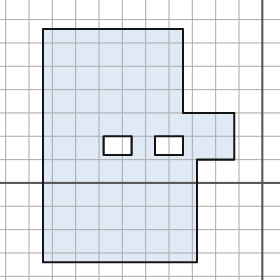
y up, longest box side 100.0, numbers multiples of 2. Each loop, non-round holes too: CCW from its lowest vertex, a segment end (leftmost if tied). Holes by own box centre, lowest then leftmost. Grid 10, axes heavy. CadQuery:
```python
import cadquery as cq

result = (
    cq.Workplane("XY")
    .moveTo(-94.0, -34.0)
    .lineTo(-28.0, -34.0)
    .lineTo(-28.0, 10.0)
    .lineTo(-12.0, 10.0)
    .lineTo(-12.0, 30.0)
    .lineTo(-34.0, 30.0)
    .lineTo(-34.0, 66.0)
    .lineTo(-94.0, 66.0)
    .close()
    .moveTo(-68.0, 12.0)
    .lineTo(-56.0, 12.0)
    .lineTo(-56.0, 20.0)
    .lineTo(-68.0, 20.0)
    .close()
    .moveTo(-46.0, 12.0)
    .lineTo(-34.0, 12.0)
    .lineTo(-34.0, 20.0)
    .lineTo(-46.0, 20.0)
    .close()
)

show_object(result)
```